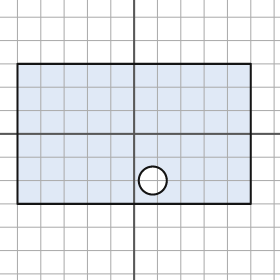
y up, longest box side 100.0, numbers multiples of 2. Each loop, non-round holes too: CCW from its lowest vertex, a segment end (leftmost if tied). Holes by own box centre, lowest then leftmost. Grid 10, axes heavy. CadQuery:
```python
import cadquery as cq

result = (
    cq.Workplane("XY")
    .moveTo(-50.0, -30.0)
    .lineTo(50.0, -30.0)
    .lineTo(50.0, 30.0)
    .lineTo(-50.0, 30.0)
    .close()
    .moveTo(8.0, -20.0)
    .circle(6.0)
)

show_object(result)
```